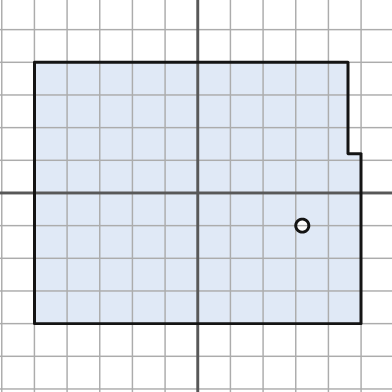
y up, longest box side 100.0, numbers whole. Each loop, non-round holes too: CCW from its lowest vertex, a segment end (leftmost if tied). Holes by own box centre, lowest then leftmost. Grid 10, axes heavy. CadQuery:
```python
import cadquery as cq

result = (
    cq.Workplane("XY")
    .moveTo(-50.0, -40.0)
    .lineTo(50.0, -40.0)
    .lineTo(50.0, 12.0)
    .lineTo(46.0, 12.0)
    .lineTo(46.0, 40.0)
    .lineTo(-50.0, 40.0)
    .close()
    .moveTo(32.0, -10.0)
    .circle(2.0)
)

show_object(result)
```